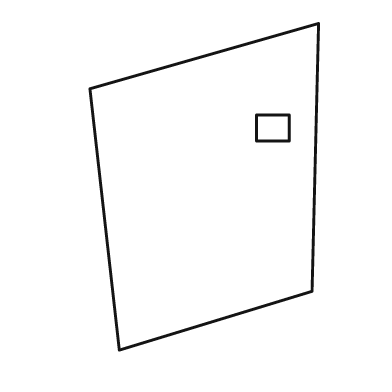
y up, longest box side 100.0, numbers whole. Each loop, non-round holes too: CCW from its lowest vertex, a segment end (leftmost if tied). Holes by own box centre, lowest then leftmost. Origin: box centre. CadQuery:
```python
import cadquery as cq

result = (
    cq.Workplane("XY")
    .moveTo(-26.0, -50.0)
    .lineTo(33.0, -32.0)
    .lineTo(35.0, 50.0)
    .lineTo(-35.0, 30.0)
    .close()
    .moveTo(16.0, 14.0)
    .lineTo(26.0, 14.0)
    .lineTo(26.0, 22.0)
    .lineTo(16.0, 22.0)
    .close()
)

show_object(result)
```